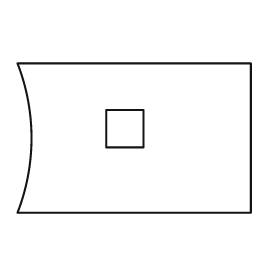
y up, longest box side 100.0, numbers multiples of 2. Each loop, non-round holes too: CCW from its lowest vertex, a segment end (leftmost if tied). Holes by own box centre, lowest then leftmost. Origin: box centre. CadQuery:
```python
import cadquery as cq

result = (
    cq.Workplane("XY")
    .moveTo(-50.0, -32.0)
    .lineTo(50.0, -32.0)
    .lineTo(50.0, 32.0)
    .lineTo(-50.0, 32.0)
    .threePointArc((-44.0, 0.0), (-50.0, -32.0))
    .close()
    .moveTo(-12.0, -4.0)
    .lineTo(4.0, -4.0)
    .lineTo(4.0, 12.0)
    .lineTo(-12.0, 12.0)
    .close()
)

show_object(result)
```